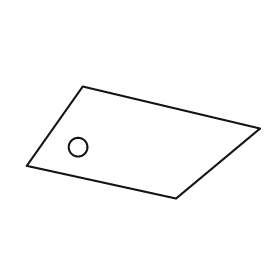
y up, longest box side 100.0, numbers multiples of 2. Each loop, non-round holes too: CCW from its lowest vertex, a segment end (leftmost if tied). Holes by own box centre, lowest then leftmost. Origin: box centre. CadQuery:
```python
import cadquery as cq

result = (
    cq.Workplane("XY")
    .moveTo(14.0, -24.0)
    .lineTo(50.0, 6.0)
    .lineTo(-26.0, 24.0)
    .lineTo(-50.0, -10.0)
    .close()
    .moveTo(-28.0, -2.0)
    .circle(4.0)
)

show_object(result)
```